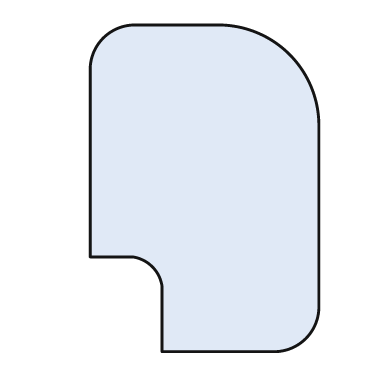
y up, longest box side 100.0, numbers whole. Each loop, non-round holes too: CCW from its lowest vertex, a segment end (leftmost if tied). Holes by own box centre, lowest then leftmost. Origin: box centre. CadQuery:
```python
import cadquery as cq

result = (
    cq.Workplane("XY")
    .moveTo(-13.0, -50.0)
    .lineTo(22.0, -50.0)
    .threePointArc((31.0, -46.0), (35.0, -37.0))
    .lineTo(35.0, 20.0)
    .threePointArc((26.0, 41.0), (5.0, 50.0))
    .lineTo(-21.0, 50.0)
    .threePointArc((-31.0, 46.0), (-35.0, 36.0))
    .lineTo(-35.0, -21.0)
    .lineTo(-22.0, -21.0)
    .threePointArc((-16.0, -24.0), (-13.0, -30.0))
    .close()
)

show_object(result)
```